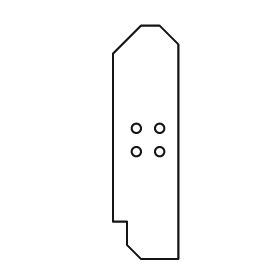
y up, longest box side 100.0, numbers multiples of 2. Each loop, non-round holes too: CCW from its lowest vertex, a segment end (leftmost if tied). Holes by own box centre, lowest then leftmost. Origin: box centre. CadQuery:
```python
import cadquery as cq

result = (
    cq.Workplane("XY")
    .moveTo(-2.0, -50.0)
    .lineTo(14.0, -50.0)
    .lineTo(14.0, 42.0)
    .lineTo(6.0, 50.0)
    .lineTo(-2.0, 50.0)
    .lineTo(-14.0, 38.0)
    .lineTo(-14.0, -34.0)
    .lineTo(-8.0, -34.0)
    .lineTo(-8.0, -44.0)
    .close()
    .moveTo(-4.0, -4.0)
    .circle(2.0)
    .moveTo(6.0, -4.0)
    .circle(2.0)
    .moveTo(-4.0, 6.0)
    .circle(2.0)
    .moveTo(6.0, 6.0)
    .circle(2.0)
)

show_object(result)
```